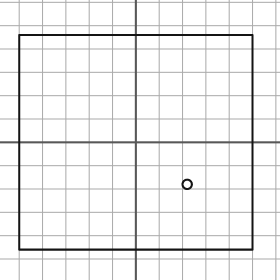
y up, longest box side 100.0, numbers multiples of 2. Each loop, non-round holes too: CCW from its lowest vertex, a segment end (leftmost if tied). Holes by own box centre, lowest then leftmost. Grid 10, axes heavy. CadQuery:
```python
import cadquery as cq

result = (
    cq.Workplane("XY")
    .moveTo(-50.0, -46.0)
    .lineTo(50.0, -46.0)
    .lineTo(50.0, 46.0)
    .lineTo(-50.0, 46.0)
    .close()
    .moveTo(22.0, -18.0)
    .circle(2.0)
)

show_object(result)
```